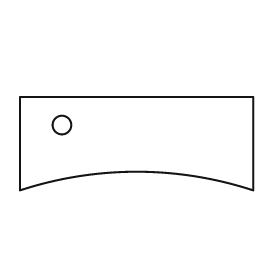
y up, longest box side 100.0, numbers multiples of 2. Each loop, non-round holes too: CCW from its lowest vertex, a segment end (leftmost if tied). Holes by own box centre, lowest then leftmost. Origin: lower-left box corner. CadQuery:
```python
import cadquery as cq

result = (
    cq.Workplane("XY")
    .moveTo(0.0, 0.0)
    .threePointArc((50.0, 8.0), (100.0, 0.0))
    .lineTo(100.0, 40.0)
    .lineTo(0.0, 40.0)
    .close()
    .moveTo(18.0, 28.0)
    .circle(4.0)
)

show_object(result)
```